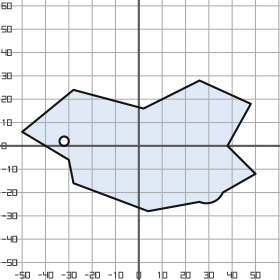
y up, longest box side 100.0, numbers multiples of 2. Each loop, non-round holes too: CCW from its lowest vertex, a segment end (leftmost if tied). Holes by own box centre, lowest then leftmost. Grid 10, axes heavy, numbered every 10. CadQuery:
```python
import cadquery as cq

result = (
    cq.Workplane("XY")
    .moveTo(4.0, -28.0)
    .lineTo(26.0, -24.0)
    .threePointArc((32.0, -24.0), (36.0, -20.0))
    .lineTo(50.0, -12.0)
    .lineTo(38.0, 0.0)
    .lineTo(48.0, 18.0)
    .lineTo(26.0, 28.0)
    .lineTo(2.0, 16.0)
    .lineTo(-28.0, 24.0)
    .lineTo(-50.0, 6.0)
    .lineTo(-30.0, -6.0)
    .lineTo(-28.0, -16.0)
    .close()
    .moveTo(-32.0, 2.0)
    .circle(2.0)
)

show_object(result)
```